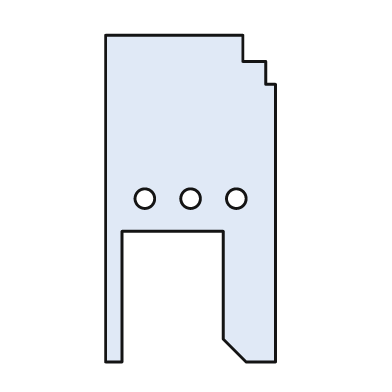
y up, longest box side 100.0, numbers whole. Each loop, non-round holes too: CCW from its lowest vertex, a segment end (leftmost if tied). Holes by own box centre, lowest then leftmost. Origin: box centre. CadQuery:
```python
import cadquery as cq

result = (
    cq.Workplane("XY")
    .moveTo(-26.0, -50.0)
    .lineTo(-21.0, -50.0)
    .lineTo(-21.0, -10.0)
    .lineTo(10.0, -10.0)
    .lineTo(10.0, -43.0)
    .lineTo(17.0, -50.0)
    .lineTo(26.0, -50.0)
    .lineTo(26.0, 35.0)
    .lineTo(23.0, 35.0)
    .lineTo(23.0, 42.0)
    .lineTo(16.0, 42.0)
    .lineTo(16.0, 50.0)
    .lineTo(-26.0, 50.0)
    .close()
    .moveTo(-14.0, 0.0)
    .circle(3.0)
    .moveTo(0.0, 0.0)
    .circle(3.0)
    .moveTo(14.0, 0.0)
    .circle(3.0)
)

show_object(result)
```